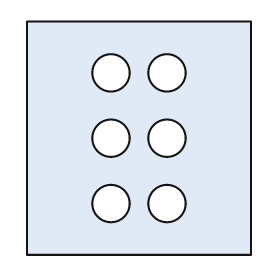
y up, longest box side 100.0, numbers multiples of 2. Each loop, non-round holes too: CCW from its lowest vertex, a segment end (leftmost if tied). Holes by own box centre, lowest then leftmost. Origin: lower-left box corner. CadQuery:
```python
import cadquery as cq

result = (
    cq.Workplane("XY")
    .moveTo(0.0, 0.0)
    .lineTo(96.0, 0.0)
    .lineTo(96.0, 100.0)
    .lineTo(0.0, 100.0)
    .close()
    .moveTo(36.0, 22.0)
    .circle(8.0)
    .moveTo(60.0, 22.0)
    .circle(8.0)
    .moveTo(36.0, 50.0)
    .circle(8.0)
    .moveTo(60.0, 50.0)
    .circle(8.0)
    .moveTo(36.0, 78.0)
    .circle(8.0)
    .moveTo(60.0, 78.0)
    .circle(8.0)
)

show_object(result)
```